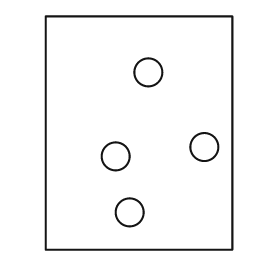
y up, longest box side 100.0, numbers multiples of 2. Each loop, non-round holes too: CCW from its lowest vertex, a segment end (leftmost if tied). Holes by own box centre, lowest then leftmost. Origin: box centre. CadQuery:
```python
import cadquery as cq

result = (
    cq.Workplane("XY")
    .moveTo(-40.0, -50.0)
    .lineTo(40.0, -50.0)
    .lineTo(40.0, 50.0)
    .lineTo(-40.0, 50.0)
    .close()
    .moveTo(-4.0, -34.0)
    .circle(6.0)
    .moveTo(-10.0, -10.0)
    .circle(6.0)
    .moveTo(28.0, -6.0)
    .circle(6.0)
    .moveTo(4.0, 26.0)
    .circle(6.0)
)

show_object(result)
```